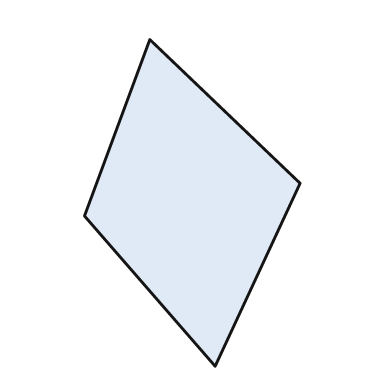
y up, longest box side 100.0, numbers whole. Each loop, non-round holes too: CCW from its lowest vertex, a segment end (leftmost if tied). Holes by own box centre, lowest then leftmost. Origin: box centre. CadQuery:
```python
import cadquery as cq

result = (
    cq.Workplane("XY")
    .moveTo(7.0, -50.0)
    .lineTo(33.0, 6.0)
    .lineTo(-13.0, 50.0)
    .lineTo(-33.0, -4.0)
    .close()
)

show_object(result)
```